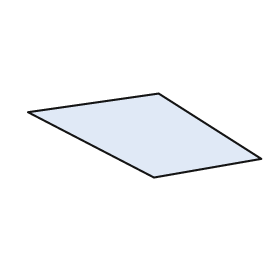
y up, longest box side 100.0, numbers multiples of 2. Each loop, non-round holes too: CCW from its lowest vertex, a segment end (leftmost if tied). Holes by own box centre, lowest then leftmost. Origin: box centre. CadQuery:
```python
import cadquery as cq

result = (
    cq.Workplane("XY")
    .moveTo(4.0, -18.0)
    .lineTo(50.0, -10.0)
    .lineTo(6.0, 18.0)
    .lineTo(-50.0, 10.0)
    .close()
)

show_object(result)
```